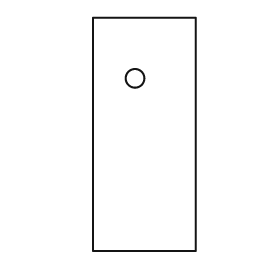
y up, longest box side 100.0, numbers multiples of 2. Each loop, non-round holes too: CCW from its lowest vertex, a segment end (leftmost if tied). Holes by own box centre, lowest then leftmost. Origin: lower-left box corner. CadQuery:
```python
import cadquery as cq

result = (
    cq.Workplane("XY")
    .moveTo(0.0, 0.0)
    .lineTo(44.0, 0.0)
    .lineTo(44.0, 100.0)
    .lineTo(0.0, 100.0)
    .close()
    .moveTo(18.0, 74.0)
    .circle(4.0)
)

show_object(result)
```